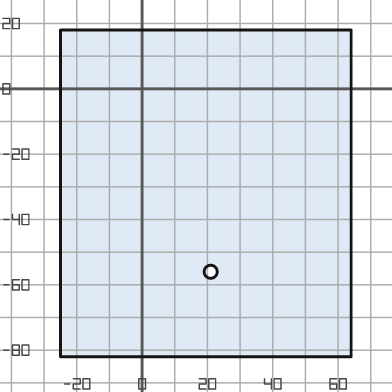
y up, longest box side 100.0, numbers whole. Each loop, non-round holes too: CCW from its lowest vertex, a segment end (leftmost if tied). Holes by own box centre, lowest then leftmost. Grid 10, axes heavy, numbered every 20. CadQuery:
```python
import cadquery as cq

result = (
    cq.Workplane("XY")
    .moveTo(-25.0, -82.0)
    .lineTo(64.0, -82.0)
    .lineTo(64.0, 18.0)
    .lineTo(-25.0, 18.0)
    .close()
    .moveTo(21.0, -56.0)
    .circle(2.0)
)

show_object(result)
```